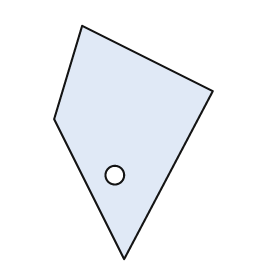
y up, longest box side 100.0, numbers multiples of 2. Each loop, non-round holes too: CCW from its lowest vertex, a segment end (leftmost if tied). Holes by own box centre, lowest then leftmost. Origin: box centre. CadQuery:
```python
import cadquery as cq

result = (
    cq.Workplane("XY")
    .moveTo(-4.0, -50.0)
    .lineTo(34.0, 22.0)
    .lineTo(-22.0, 50.0)
    .lineTo(-34.0, 10.0)
    .close()
    .moveTo(-8.0, -14.0)
    .circle(4.0)
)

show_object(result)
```